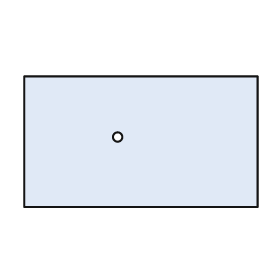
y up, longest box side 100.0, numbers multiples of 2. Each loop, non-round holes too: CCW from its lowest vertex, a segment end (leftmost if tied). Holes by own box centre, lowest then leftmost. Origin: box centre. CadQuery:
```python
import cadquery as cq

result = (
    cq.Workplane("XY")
    .moveTo(-50.0, -28.0)
    .lineTo(50.0, -28.0)
    .lineTo(50.0, 28.0)
    .lineTo(-50.0, 28.0)
    .close()
    .moveTo(-10.0, 2.0)
    .circle(2.0)
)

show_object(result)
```